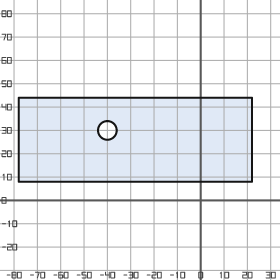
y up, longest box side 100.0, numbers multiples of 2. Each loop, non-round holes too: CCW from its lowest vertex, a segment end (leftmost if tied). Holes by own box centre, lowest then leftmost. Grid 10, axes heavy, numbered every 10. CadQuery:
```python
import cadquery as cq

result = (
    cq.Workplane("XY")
    .moveTo(-78.0, 8.0)
    .lineTo(22.0, 8.0)
    .lineTo(22.0, 44.0)
    .lineTo(-78.0, 44.0)
    .close()
    .moveTo(-40.0, 30.0)
    .circle(4.0)
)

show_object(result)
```